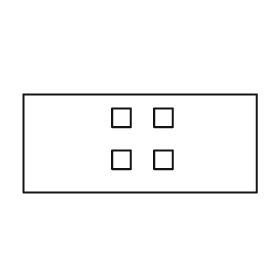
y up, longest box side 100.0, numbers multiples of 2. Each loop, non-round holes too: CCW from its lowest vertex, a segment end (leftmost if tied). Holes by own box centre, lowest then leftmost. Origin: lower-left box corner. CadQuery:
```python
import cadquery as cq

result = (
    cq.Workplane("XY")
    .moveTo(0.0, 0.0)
    .lineTo(100.0, 0.0)
    .lineTo(100.0, 42.0)
    .lineTo(0.0, 42.0)
    .close()
    .moveTo(38.0, 10.0)
    .lineTo(46.0, 10.0)
    .lineTo(46.0, 18.0)
    .lineTo(38.0, 18.0)
    .close()
    .moveTo(56.0, 10.0)
    .lineTo(64.0, 10.0)
    .lineTo(64.0, 18.0)
    .lineTo(56.0, 18.0)
    .close()
    .moveTo(38.0, 28.0)
    .lineTo(46.0, 28.0)
    .lineTo(46.0, 36.0)
    .lineTo(38.0, 36.0)
    .close()
    .moveTo(56.0, 28.0)
    .lineTo(64.0, 28.0)
    .lineTo(64.0, 36.0)
    .lineTo(56.0, 36.0)
    .close()
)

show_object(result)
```